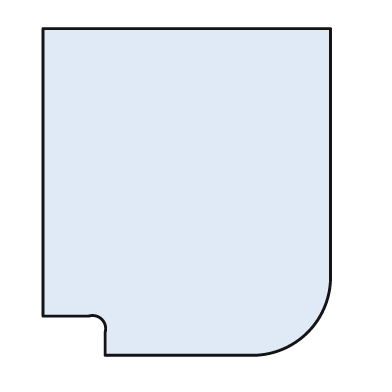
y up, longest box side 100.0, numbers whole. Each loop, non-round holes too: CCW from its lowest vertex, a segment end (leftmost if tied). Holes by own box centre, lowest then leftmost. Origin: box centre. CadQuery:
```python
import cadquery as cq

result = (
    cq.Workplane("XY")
    .moveTo(-25.0, -50.0)
    .lineTo(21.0, -50.0)
    .threePointArc((37.0, -43.0), (44.0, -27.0))
    .lineTo(44.0, 50.0)
    .lineTo(-44.0, 50.0)
    .lineTo(-44.0, -38.0)
    .lineTo(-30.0, -38.0)
    .threePointArc((-26.0, -39.0), (-25.0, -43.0))
    .close()
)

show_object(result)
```